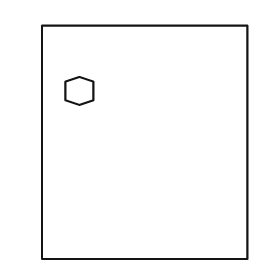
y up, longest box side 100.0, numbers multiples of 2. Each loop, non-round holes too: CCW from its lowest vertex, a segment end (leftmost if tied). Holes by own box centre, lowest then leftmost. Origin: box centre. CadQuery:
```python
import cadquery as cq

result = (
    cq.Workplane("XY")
    .moveTo(-44.0, -50.0)
    .lineTo(44.0, -50.0)
    .lineTo(44.0, 50.0)
    .lineTo(-44.0, 50.0)
    .close()
    .moveTo(-28.0, 16.0)
    .lineTo(-22.0, 18.0)
    .lineTo(-22.0, 26.0)
    .lineTo(-28.0, 28.0)
    .lineTo(-34.0, 26.0)
    .lineTo(-34.0, 18.0)
    .close()
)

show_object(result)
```